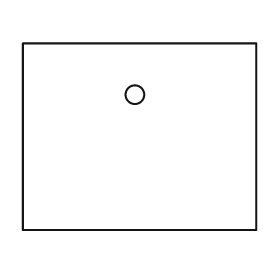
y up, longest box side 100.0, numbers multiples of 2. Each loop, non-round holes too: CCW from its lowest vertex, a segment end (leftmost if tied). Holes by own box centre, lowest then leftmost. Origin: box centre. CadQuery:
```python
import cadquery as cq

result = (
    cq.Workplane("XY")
    .moveTo(-50.0, -40.0)
    .lineTo(50.0, -40.0)
    .lineTo(50.0, 40.0)
    .lineTo(-50.0, 40.0)
    .close()
    .moveTo(-2.0, 18.0)
    .circle(4.0)
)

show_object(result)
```